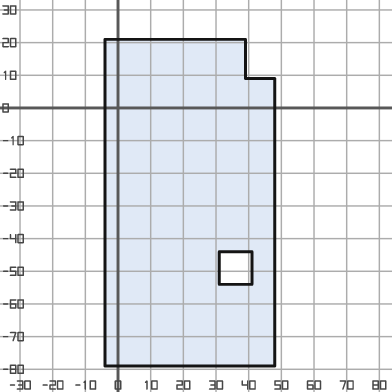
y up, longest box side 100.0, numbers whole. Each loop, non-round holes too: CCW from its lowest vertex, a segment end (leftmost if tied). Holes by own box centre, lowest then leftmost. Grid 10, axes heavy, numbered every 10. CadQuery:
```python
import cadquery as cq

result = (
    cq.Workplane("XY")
    .moveTo(-4.0, -79.0)
    .lineTo(48.0, -79.0)
    .lineTo(48.0, 9.0)
    .lineTo(39.0, 9.0)
    .lineTo(39.0, 21.0)
    .lineTo(-4.0, 21.0)
    .close()
    .moveTo(31.0, -54.0)
    .lineTo(41.0, -54.0)
    .lineTo(41.0, -44.0)
    .lineTo(31.0, -44.0)
    .close()
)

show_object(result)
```